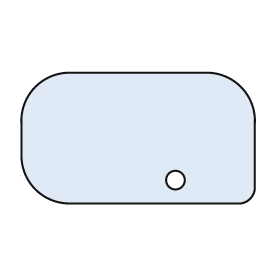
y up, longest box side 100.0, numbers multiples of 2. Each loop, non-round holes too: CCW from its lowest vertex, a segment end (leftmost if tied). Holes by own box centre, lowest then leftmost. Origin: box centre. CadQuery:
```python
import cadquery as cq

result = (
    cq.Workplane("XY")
    .moveTo(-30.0, -28.0)
    .lineTo(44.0, -28.0)
    .threePointArc((48.0, -26.0), (50.0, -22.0))
    .lineTo(50.0, 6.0)
    .threePointArc((44.0, 22.0), (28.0, 28.0))
    .lineTo(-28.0, 28.0)
    .threePointArc((-44.0, 22.0), (-50.0, 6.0))
    .lineTo(-50.0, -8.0)
    .threePointArc((-44.0, -22.0), (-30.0, -28.0))
    .close()
    .moveTo(16.0, -18.0)
    .circle(4.0)
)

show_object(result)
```